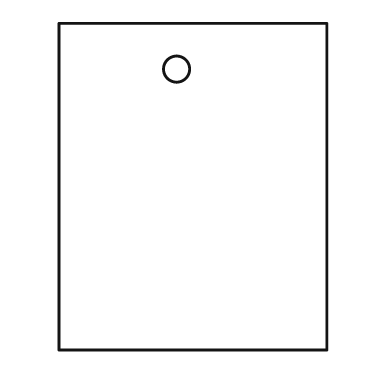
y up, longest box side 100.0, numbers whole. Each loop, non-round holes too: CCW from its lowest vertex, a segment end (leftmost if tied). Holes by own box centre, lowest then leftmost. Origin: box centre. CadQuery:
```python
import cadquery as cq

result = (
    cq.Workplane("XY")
    .moveTo(-41.0, -50.0)
    .lineTo(41.0, -50.0)
    .lineTo(41.0, 50.0)
    .lineTo(-41.0, 50.0)
    .close()
    .moveTo(-5.0, 36.0)
    .circle(4.0)
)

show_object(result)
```